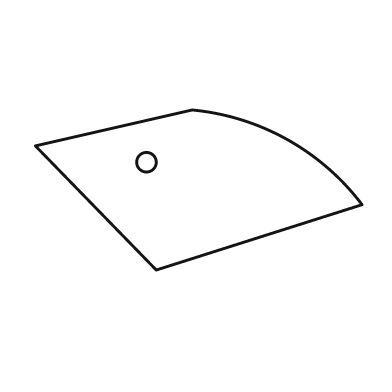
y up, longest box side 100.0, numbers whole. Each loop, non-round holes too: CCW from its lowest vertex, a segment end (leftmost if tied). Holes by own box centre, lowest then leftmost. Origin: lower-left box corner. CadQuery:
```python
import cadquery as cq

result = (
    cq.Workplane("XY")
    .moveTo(37.0, 0.0)
    .lineTo(100.0, 20.0)
    .threePointArc((77.0, 40.0), (48.0, 49.0))
    .lineTo(0.0, 38.0)
    .close()
    .moveTo(34.0, 33.0)
    .circle(3.0)
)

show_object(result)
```